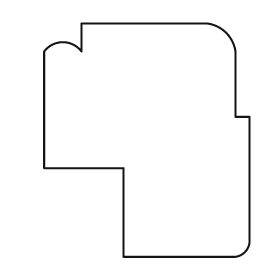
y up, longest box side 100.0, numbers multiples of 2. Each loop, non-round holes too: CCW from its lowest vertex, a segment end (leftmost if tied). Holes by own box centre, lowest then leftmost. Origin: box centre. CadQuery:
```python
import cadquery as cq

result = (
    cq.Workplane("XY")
    .moveTo(-10.0, -50.0)
    .lineTo(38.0, -50.0)
    .threePointArc((42.0, -48.0), (44.0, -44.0))
    .lineTo(44.0, 10.0)
    .lineTo(38.0, 10.0)
    .lineTo(38.0, 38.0)
    .threePointArc((34.0, 46.0), (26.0, 50.0))
    .lineTo(-28.0, 50.0)
    .lineTo(-28.0, 38.0)
    .threePointArc((-36.0, 42.0), (-44.0, 38.0))
    .lineTo(-44.0, -12.0)
    .lineTo(-10.0, -12.0)
    .close()
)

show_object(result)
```